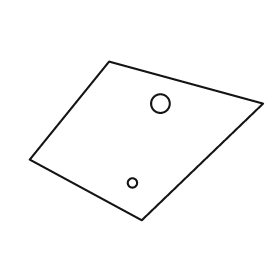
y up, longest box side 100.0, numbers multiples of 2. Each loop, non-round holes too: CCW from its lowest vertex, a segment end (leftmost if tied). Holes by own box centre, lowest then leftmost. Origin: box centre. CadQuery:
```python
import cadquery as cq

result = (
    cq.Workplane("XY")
    .moveTo(-2.0, -34.0)
    .lineTo(50.0, 16.0)
    .lineTo(-16.0, 34.0)
    .lineTo(-50.0, -8.0)
    .close()
    .moveTo(-6.0, -18.0)
    .circle(2.0)
    .moveTo(6.0, 16.0)
    .circle(4.0)
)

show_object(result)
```